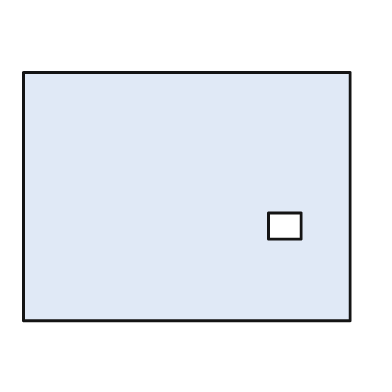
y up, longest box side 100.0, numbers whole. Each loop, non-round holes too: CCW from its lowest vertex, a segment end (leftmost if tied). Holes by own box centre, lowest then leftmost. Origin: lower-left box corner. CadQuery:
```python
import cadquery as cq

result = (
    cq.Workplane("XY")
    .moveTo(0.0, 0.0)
    .lineTo(100.0, 0.0)
    .lineTo(100.0, 76.0)
    .lineTo(0.0, 76.0)
    .close()
    .moveTo(75.0, 25.0)
    .lineTo(85.0, 25.0)
    .lineTo(85.0, 33.0)
    .lineTo(75.0, 33.0)
    .close()
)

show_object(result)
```